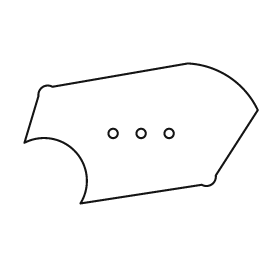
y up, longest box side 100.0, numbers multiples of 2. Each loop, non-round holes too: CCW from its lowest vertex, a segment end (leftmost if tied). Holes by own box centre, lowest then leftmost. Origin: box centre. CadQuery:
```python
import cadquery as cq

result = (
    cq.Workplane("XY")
    .moveTo(-26.0, -30.0)
    .lineTo(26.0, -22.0)
    .threePointArc((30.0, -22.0), (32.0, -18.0))
    .lineTo(50.0, 10.0)
    .threePointArc((38.0, 24.0), (20.0, 30.0))
    .lineTo(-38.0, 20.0)
    .threePointArc((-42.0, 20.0), (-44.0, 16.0))
    .lineTo(-50.0, -4.0)
    .threePointArc((-28.0, -8.0), (-26.0, -30.0))
    .close()
    .moveTo(-12.0, 0.0)
    .circle(2.0)
    .moveTo(0.0, 0.0)
    .circle(2.0)
    .moveTo(12.0, 0.0)
    .circle(2.0)
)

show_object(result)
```